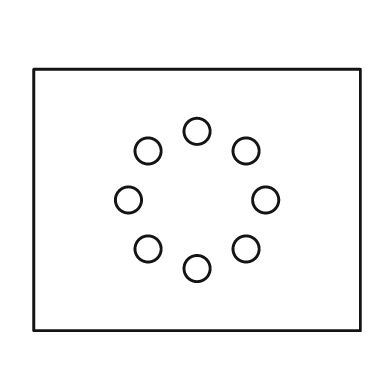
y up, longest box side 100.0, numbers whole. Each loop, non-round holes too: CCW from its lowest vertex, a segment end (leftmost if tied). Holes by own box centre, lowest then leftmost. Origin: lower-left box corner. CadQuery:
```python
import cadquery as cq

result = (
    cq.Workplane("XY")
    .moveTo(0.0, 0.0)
    .lineTo(100.0, 0.0)
    .lineTo(100.0, 80.0)
    .lineTo(0.0, 80.0)
    .close()
    .moveTo(50.0, 19.0)
    .circle(4.0)
    .moveTo(35.0, 25.0)
    .circle(4.0)
    .moveTo(65.0, 25.0)
    .circle(4.0)
    .moveTo(29.0, 40.0)
    .circle(4.0)
    .moveTo(71.0, 40.0)
    .circle(4.0)
    .moveTo(35.0, 55.0)
    .circle(4.0)
    .moveTo(65.0, 55.0)
    .circle(4.0)
    .moveTo(50.0, 61.0)
    .circle(4.0)
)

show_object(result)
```